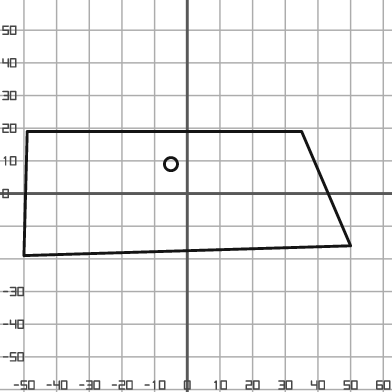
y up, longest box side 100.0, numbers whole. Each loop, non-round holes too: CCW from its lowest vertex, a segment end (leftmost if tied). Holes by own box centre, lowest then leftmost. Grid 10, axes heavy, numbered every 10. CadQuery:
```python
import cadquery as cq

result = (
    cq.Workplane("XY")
    .moveTo(-50.0, -19.0)
    .lineTo(50.0, -16.0)
    .lineTo(35.0, 19.0)
    .lineTo(-49.0, 19.0)
    .close()
    .moveTo(-5.0, 9.0)
    .circle(2.0)
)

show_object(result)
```